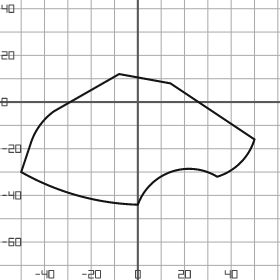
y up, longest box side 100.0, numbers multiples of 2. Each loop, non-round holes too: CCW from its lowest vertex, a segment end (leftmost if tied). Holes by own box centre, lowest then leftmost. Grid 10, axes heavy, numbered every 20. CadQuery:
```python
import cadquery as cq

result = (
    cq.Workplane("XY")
    .moveTo(0.0, -44.0)
    .threePointArc((14.0, -30.0), (34.0, -32.0))
    .threePointArc((44.0, -26.0), (50.0, -16.0))
    .lineTo(14.0, 8.0)
    .lineTo(-8.0, 12.0)
    .lineTo(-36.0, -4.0)
    .threePointArc((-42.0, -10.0), (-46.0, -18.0))
    .lineTo(-50.0, -30.0)
    .threePointArc((-26.0, -40.0), (0.0, -44.0))
    .close()
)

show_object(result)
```